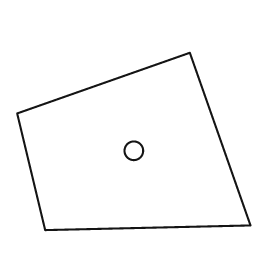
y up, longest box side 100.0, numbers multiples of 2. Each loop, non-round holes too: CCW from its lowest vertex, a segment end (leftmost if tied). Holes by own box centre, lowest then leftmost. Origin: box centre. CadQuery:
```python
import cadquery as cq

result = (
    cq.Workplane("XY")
    .moveTo(-38.0, -38.0)
    .lineTo(50.0, -36.0)
    .lineTo(24.0, 38.0)
    .lineTo(-50.0, 12.0)
    .close()
    .moveTo(0.0, -4.0)
    .circle(4.0)
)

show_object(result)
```